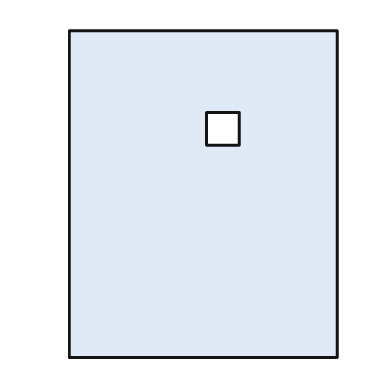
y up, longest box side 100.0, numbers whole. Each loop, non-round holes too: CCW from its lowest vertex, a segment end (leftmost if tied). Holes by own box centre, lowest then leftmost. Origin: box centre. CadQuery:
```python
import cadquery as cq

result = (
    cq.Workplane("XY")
    .moveTo(-41.0, -50.0)
    .lineTo(41.0, -50.0)
    .lineTo(41.0, 50.0)
    .lineTo(-41.0, 50.0)
    .close()
    .moveTo(1.0, 15.0)
    .lineTo(11.0, 15.0)
    .lineTo(11.0, 25.0)
    .lineTo(1.0, 25.0)
    .close()
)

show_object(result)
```